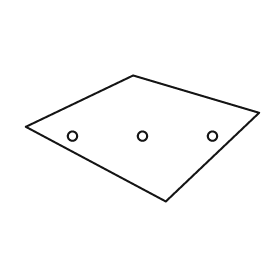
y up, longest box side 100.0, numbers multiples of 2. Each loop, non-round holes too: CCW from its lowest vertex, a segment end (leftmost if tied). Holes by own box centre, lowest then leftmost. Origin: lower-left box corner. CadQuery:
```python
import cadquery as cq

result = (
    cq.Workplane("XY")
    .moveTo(60.0, 0.0)
    .lineTo(100.0, 38.0)
    .lineTo(46.0, 54.0)
    .lineTo(0.0, 32.0)
    .close()
    .moveTo(20.0, 28.0)
    .circle(2.0)
    .moveTo(50.0, 28.0)
    .circle(2.0)
    .moveTo(80.0, 28.0)
    .circle(2.0)
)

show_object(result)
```